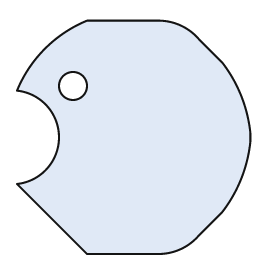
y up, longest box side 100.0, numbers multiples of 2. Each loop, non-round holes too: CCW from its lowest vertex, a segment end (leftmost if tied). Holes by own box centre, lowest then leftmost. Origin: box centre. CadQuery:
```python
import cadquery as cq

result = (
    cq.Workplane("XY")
    .moveTo(-20.0, -50.0)
    .lineTo(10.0, -50.0)
    .threePointArc((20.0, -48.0), (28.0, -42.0))
    .lineTo(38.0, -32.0)
    .threePointArc((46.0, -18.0), (50.0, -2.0))
    .lineTo(50.0, 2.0)
    .threePointArc((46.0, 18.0), (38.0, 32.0))
    .lineTo(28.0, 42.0)
    .threePointArc((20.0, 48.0), (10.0, 50.0))
    .lineTo(-20.0, 50.0)
    .threePointArc((-38.0, 38.0), (-50.0, 20.0))
    .threePointArc((-32.0, 0.0), (-50.0, -20.0))
    .close()
    .moveTo(-26.0, 22.0)
    .circle(6.0)
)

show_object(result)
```